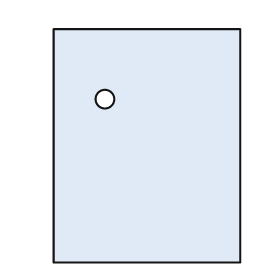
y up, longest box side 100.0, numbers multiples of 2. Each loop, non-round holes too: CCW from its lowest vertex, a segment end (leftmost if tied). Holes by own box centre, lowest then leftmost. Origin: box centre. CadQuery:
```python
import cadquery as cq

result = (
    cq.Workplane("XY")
    .moveTo(-40.0, -50.0)
    .lineTo(40.0, -50.0)
    .lineTo(40.0, 50.0)
    .lineTo(-40.0, 50.0)
    .close()
    .moveTo(-18.0, 20.0)
    .circle(4.0)
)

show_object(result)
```